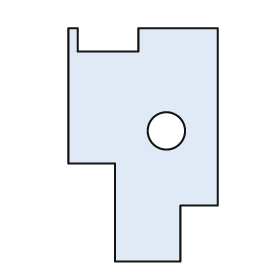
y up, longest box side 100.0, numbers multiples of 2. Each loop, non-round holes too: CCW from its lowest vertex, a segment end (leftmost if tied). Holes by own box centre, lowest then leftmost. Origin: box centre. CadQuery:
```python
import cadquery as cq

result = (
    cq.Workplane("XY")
    .moveTo(-12.0, -50.0)
    .lineTo(16.0, -50.0)
    .lineTo(16.0, -26.0)
    .lineTo(32.0, -26.0)
    .lineTo(32.0, 50.0)
    .lineTo(-2.0, 50.0)
    .lineTo(-2.0, 40.0)
    .lineTo(-28.0, 40.0)
    .lineTo(-28.0, 50.0)
    .lineTo(-32.0, 50.0)
    .lineTo(-32.0, -8.0)
    .lineTo(-12.0, -8.0)
    .close()
    .moveTo(10.0, 6.0)
    .circle(8.0)
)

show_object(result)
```